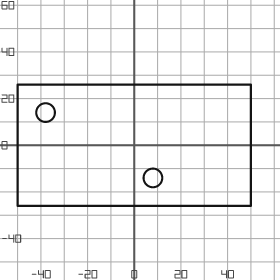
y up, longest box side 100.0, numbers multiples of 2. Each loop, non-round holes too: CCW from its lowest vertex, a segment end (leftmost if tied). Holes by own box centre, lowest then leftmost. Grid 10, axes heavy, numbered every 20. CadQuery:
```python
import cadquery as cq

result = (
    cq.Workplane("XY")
    .moveTo(-50.0, -26.0)
    .lineTo(50.0, -26.0)
    .lineTo(50.0, 26.0)
    .lineTo(-50.0, 26.0)
    .close()
    .moveTo(8.0, -14.0)
    .circle(4.0)
    .moveTo(-38.0, 14.0)
    .circle(4.0)
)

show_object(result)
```